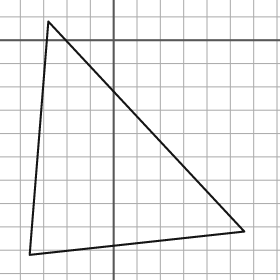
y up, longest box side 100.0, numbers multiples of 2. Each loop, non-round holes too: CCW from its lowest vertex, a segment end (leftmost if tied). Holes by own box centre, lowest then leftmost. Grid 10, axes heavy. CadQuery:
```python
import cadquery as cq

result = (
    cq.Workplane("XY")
    .moveTo(-36.0, -92.0)
    .lineTo(56.0, -82.0)
    .lineTo(-28.0, 8.0)
    .close()
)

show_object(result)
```